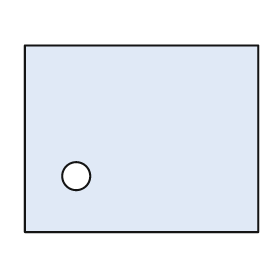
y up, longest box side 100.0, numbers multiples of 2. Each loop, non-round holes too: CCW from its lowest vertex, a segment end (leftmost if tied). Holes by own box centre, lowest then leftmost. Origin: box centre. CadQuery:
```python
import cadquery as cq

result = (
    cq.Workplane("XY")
    .moveTo(-50.0, -40.0)
    .lineTo(50.0, -40.0)
    .lineTo(50.0, 40.0)
    .lineTo(-50.0, 40.0)
    .close()
    .moveTo(-28.0, -16.0)
    .circle(6.0)
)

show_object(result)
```